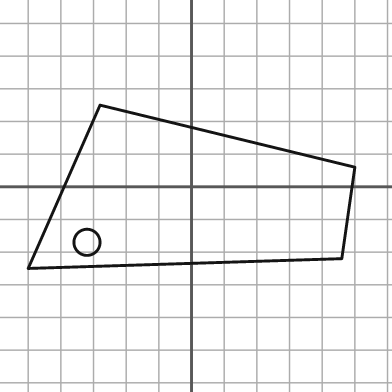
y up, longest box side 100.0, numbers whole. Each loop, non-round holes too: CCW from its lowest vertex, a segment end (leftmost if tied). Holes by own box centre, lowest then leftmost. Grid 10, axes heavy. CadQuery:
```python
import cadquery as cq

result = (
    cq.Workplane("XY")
    .moveTo(-50.0, -25.0)
    .lineTo(46.0, -22.0)
    .lineTo(50.0, 6.0)
    .lineTo(-28.0, 25.0)
    .close()
    .moveTo(-32.0, -17.0)
    .circle(4.0)
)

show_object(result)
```